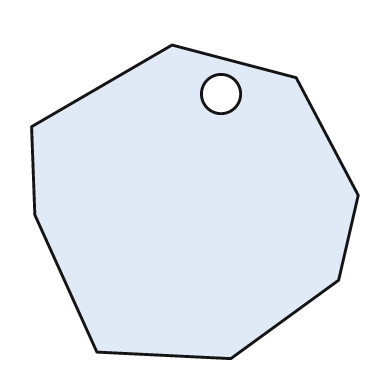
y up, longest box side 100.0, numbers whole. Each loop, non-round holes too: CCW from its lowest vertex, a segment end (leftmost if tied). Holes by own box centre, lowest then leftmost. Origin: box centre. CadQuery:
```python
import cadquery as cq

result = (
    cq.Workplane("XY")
    .moveTo(11.0, -48.0)
    .lineTo(44.0, -24.0)
    .lineTo(50.0, 2.0)
    .lineTo(31.0, 38.0)
    .lineTo(-7.0, 48.0)
    .lineTo(-50.0, 23.0)
    .lineTo(-49.0, -4.0)
    .lineTo(-30.0, -46.0)
    .close()
    .moveTo(8.0, 33.0)
    .circle(6.0)
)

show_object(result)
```